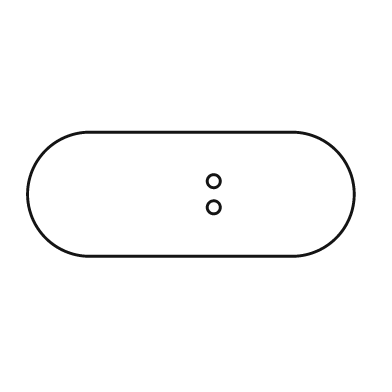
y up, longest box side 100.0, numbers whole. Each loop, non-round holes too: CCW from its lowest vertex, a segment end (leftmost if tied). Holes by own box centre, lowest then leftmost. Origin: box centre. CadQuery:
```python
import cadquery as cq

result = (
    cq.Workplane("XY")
    .moveTo(-31.0, -19.0)
    .lineTo(31.0, -19.0)
    .threePointArc((50.0, 0.0), (31.0, 19.0))
    .lineTo(-31.0, 19.0)
    .threePointArc((-50.0, 0.0), (-31.0, -19.0))
    .close()
    .moveTo(7.0, -4.0)
    .circle(2.0)
    .moveTo(7.0, 4.0)
    .circle(2.0)
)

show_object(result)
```